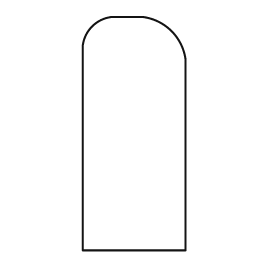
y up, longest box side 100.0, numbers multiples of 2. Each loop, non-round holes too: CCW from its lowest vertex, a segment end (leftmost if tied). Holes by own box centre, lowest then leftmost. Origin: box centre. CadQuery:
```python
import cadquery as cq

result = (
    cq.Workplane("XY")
    .moveTo(-22.0, -50.0)
    .lineTo(22.0, -50.0)
    .lineTo(22.0, 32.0)
    .threePointArc((16.0, 44.0), (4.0, 50.0))
    .lineTo(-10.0, 50.0)
    .threePointArc((-18.0, 46.0), (-22.0, 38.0))
    .close()
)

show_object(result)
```